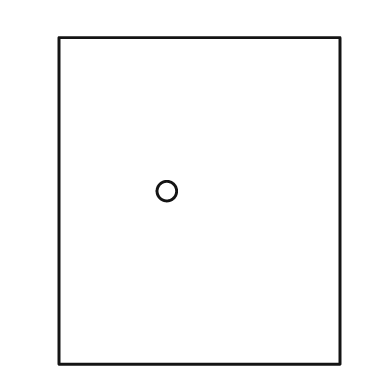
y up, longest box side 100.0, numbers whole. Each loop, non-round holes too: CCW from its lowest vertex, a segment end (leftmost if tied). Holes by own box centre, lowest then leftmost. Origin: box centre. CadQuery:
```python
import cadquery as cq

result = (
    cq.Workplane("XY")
    .moveTo(-43.0, -50.0)
    .lineTo(43.0, -50.0)
    .lineTo(43.0, 50.0)
    .lineTo(-43.0, 50.0)
    .close()
    .moveTo(-10.0, 3.0)
    .circle(3.0)
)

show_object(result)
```